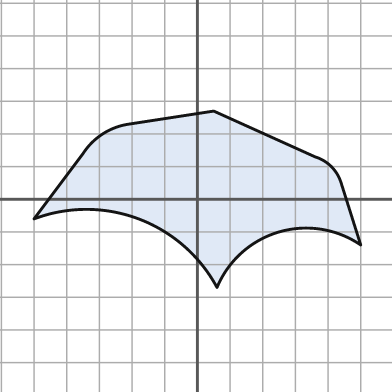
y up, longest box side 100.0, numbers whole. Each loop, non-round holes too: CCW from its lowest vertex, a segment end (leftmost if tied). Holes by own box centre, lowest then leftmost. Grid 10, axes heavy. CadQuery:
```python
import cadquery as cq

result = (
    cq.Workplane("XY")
    .moveTo(6.0, -27.0)
    .threePointArc((25.0, -10.0), (50.0, -14.0))
    .lineTo(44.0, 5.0)
    .threePointArc((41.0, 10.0), (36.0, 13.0))
    .lineTo(5.0, 27.0)
    .lineTo(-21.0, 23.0)
    .threePointArc((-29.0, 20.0), (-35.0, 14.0))
    .lineTo(-50.0, -6.0)
    .threePointArc((-18.0, -6.0), (6.0, -27.0))
    .close()
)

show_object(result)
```